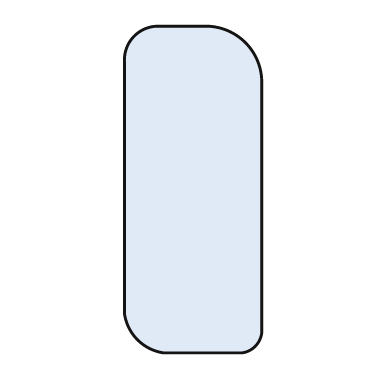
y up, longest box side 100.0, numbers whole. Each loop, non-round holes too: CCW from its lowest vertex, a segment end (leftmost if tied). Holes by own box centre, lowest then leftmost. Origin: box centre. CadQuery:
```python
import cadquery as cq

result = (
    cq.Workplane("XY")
    .moveTo(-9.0, -50.0)
    .lineTo(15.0, -50.0)
    .threePointArc((19.0, -48.0), (21.0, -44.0))
    .lineTo(21.0, 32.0)
    .threePointArc((16.0, 45.0), (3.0, 50.0))
    .lineTo(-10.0, 50.0)
    .threePointArc((-18.0, 47.0), (-21.0, 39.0))
    .lineTo(-21.0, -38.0)
    .threePointArc((-17.0, -46.0), (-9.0, -50.0))
    .close()
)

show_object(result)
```